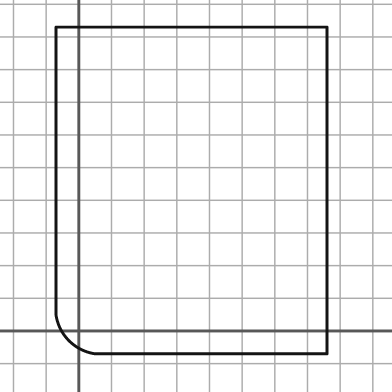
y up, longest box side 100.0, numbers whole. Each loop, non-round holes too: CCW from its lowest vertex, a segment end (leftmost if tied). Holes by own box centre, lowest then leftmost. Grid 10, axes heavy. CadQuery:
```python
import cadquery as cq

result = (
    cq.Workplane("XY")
    .moveTo(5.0, -7.0)
    .lineTo(76.0, -7.0)
    .lineTo(76.0, 93.0)
    .lineTo(-7.0, 93.0)
    .lineTo(-7.0, 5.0)
    .threePointArc((-3.0, -3.0), (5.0, -7.0))
    .close()
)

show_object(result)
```